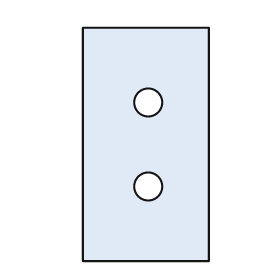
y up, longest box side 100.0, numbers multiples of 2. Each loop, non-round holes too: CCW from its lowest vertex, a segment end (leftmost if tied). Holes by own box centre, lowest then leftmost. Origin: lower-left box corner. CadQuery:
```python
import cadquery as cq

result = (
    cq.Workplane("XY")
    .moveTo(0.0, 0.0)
    .lineTo(54.0, 0.0)
    .lineTo(54.0, 100.0)
    .lineTo(0.0, 100.0)
    .close()
    .moveTo(28.0, 32.0)
    .circle(6.0)
    .moveTo(28.0, 68.0)
    .circle(6.0)
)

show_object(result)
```